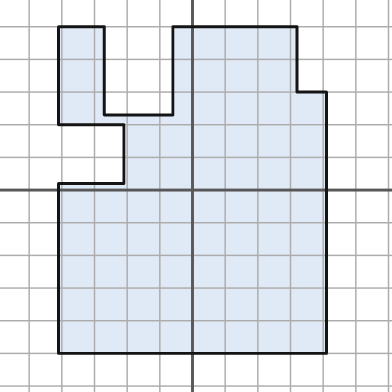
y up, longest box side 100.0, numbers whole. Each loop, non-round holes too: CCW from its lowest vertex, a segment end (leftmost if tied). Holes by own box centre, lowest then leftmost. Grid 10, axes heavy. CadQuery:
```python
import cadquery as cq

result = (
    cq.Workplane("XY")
    .moveTo(-41.0, -50.0)
    .lineTo(41.0, -50.0)
    .lineTo(41.0, 30.0)
    .lineTo(32.0, 30.0)
    .lineTo(32.0, 50.0)
    .lineTo(-6.0, 50.0)
    .lineTo(-6.0, 23.0)
    .lineTo(-27.0, 23.0)
    .lineTo(-27.0, 50.0)
    .lineTo(-41.0, 50.0)
    .lineTo(-41.0, 20.0)
    .lineTo(-21.0, 20.0)
    .lineTo(-21.0, 2.0)
    .lineTo(-41.0, 2.0)
    .close()
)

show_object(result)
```